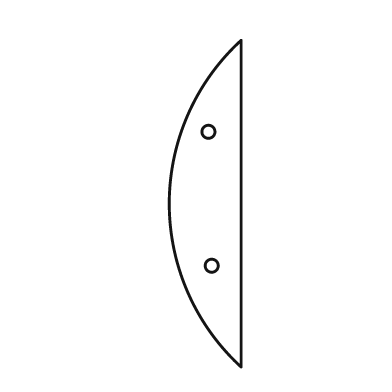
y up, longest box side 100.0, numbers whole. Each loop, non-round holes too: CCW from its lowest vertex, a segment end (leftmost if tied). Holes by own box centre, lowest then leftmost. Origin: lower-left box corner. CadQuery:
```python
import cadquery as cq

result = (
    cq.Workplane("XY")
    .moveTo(22.0, 0.0)
    .lineTo(22.0, 100.0)
    .threePointArc((0.0, 50.0), (22.0, 0.0))
    .close()
    .moveTo(13.0, 31.0)
    .circle(2.0)
    .moveTo(12.0, 72.0)
    .circle(2.0)
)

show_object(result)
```